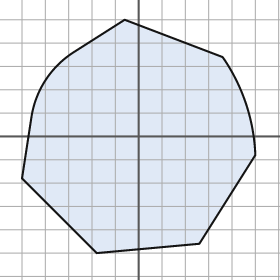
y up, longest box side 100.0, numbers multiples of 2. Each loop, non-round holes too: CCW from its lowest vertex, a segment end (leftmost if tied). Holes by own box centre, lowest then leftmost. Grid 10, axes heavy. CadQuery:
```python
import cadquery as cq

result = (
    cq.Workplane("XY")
    .moveTo(-18.0, -50.0)
    .lineTo(26.0, -46.0)
    .lineTo(50.0, -8.0)
    .threePointArc((46.0, 14.0), (36.0, 34.0))
    .lineTo(-6.0, 50.0)
    .lineTo(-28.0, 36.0)
    .threePointArc((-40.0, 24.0), (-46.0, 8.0))
    .lineTo(-50.0, -18.0)
    .close()
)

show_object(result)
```